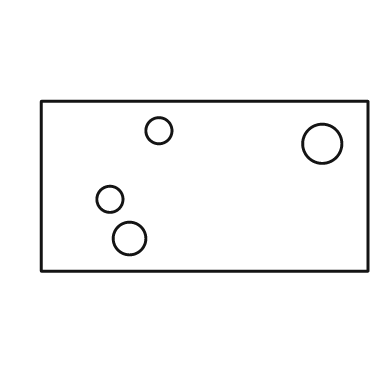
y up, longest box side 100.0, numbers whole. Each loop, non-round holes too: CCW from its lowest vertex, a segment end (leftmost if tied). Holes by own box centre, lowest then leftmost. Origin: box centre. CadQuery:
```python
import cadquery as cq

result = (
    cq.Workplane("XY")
    .moveTo(-50.0, -26.0)
    .lineTo(50.0, -26.0)
    .lineTo(50.0, 26.0)
    .lineTo(-50.0, 26.0)
    .close()
    .moveTo(-23.0, -16.0)
    .circle(5.0)
    .moveTo(-29.0, -4.0)
    .circle(4.0)
    .moveTo(36.0, 13.0)
    .circle(6.0)
    .moveTo(-14.0, 17.0)
    .circle(4.0)
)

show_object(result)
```